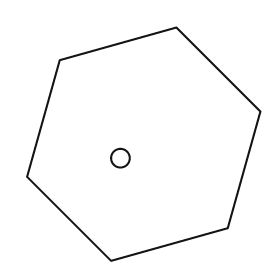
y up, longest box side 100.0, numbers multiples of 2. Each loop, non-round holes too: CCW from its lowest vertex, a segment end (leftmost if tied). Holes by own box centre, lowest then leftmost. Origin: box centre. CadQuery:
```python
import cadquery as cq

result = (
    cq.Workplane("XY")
    .moveTo(-14.0, -50.0)
    .lineTo(36.0, -36.0)
    .lineTo(50.0, 14.0)
    .lineTo(14.0, 50.0)
    .lineTo(-36.0, 36.0)
    .lineTo(-50.0, -14.0)
    .close()
    .moveTo(-10.0, -6.0)
    .circle(4.0)
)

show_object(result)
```